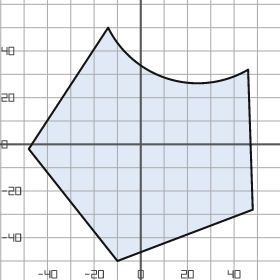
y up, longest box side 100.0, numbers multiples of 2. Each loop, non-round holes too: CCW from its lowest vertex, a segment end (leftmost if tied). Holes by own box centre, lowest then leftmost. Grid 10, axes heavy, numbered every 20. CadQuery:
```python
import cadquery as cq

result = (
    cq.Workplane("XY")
    .moveTo(-10.0, -50.0)
    .lineTo(48.0, -28.0)
    .lineTo(46.0, 32.0)
    .threePointArc((12.0, 28.0), (-14.0, 50.0))
    .lineTo(-48.0, -2.0)
    .close()
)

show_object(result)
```